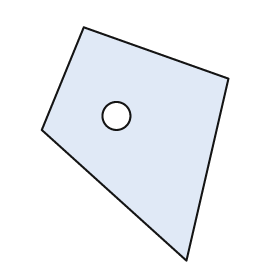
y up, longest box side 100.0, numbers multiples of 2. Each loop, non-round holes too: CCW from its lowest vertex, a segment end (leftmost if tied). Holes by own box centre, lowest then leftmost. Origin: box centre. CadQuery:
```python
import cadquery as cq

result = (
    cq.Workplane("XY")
    .moveTo(22.0, -50.0)
    .lineTo(40.0, 28.0)
    .lineTo(-22.0, 50.0)
    .lineTo(-40.0, 6.0)
    .close()
    .moveTo(-8.0, 12.0)
    .circle(6.0)
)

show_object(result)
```